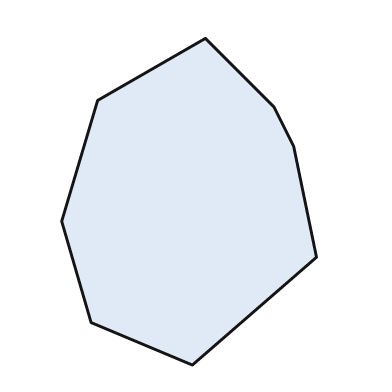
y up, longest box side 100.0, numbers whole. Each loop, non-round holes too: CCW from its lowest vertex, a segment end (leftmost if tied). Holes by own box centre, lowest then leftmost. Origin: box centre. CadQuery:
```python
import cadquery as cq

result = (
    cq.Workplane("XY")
    .moveTo(1.0, -50.0)
    .lineTo(39.0, -17.0)
    .lineTo(32.0, 17.0)
    .lineTo(26.0, 29.0)
    .lineTo(5.0, 50.0)
    .lineTo(-28.0, 31.0)
    .lineTo(-39.0, -6.0)
    .lineTo(-30.0, -37.0)
    .close()
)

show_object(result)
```